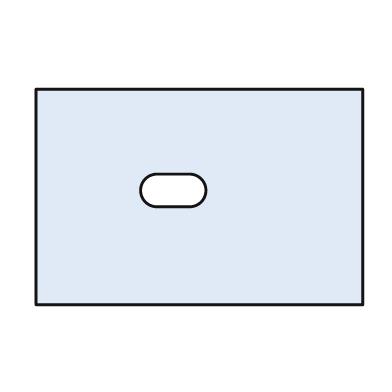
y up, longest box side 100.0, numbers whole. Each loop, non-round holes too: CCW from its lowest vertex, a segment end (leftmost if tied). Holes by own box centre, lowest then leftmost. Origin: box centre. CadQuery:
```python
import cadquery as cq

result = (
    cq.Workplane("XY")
    .moveTo(-50.0, -33.0)
    .lineTo(50.0, -33.0)
    .lineTo(50.0, 33.0)
    .lineTo(-50.0, 33.0)
    .close()
    .moveTo(-13.0, -3.0)
    .lineTo(-3.0, -3.0)
    .threePointArc((2.0, 2.0), (-3.0, 7.0))
    .lineTo(-13.0, 7.0)
    .threePointArc((-18.0, 2.0), (-13.0, -3.0))
    .close()
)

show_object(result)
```